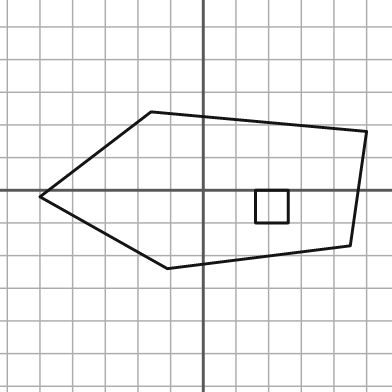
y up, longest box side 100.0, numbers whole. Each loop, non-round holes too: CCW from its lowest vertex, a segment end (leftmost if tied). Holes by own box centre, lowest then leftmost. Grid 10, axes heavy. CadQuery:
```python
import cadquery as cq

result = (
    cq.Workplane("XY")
    .moveTo(-11.0, -24.0)
    .lineTo(45.0, -17.0)
    .lineTo(50.0, 18.0)
    .lineTo(-16.0, 24.0)
    .lineTo(-50.0, -2.0)
    .close()
    .moveTo(16.0, -10.0)
    .lineTo(26.0, -10.0)
    .lineTo(26.0, 0.0)
    .lineTo(16.0, 0.0)
    .close()
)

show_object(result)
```